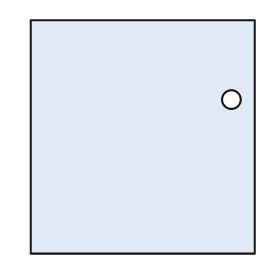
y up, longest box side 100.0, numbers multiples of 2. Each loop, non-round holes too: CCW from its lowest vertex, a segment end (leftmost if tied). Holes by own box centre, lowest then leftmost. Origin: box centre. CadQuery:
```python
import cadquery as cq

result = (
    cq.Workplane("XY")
    .moveTo(-48.0, -50.0)
    .lineTo(48.0, -50.0)
    .lineTo(48.0, 50.0)
    .lineTo(-48.0, 50.0)
    .close()
    .moveTo(38.0, 16.0)
    .circle(4.0)
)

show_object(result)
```